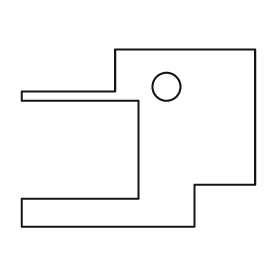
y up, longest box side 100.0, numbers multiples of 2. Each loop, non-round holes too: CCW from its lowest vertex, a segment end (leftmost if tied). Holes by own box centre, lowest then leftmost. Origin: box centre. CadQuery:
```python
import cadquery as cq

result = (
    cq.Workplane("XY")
    .moveTo(-50.0, -38.0)
    .lineTo(24.0, -38.0)
    .lineTo(24.0, -20.0)
    .lineTo(50.0, -20.0)
    .lineTo(50.0, 38.0)
    .lineTo(-10.0, 38.0)
    .lineTo(-10.0, 20.0)
    .lineTo(-50.0, 20.0)
    .lineTo(-50.0, 16.0)
    .lineTo(0.0, 16.0)
    .lineTo(0.0, -26.0)
    .lineTo(-50.0, -26.0)
    .close()
    .moveTo(12.0, 22.0)
    .circle(6.0)
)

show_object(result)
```